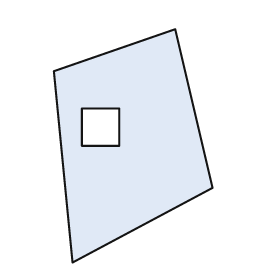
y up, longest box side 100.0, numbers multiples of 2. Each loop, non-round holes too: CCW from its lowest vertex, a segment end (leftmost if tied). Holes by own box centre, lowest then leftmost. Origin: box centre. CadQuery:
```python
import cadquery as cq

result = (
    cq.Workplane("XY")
    .moveTo(-26.0, -50.0)
    .lineTo(34.0, -18.0)
    .lineTo(18.0, 50.0)
    .lineTo(-34.0, 32.0)
    .close()
    .moveTo(-22.0, 0.0)
    .lineTo(-6.0, 0.0)
    .lineTo(-6.0, 16.0)
    .lineTo(-22.0, 16.0)
    .close()
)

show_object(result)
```